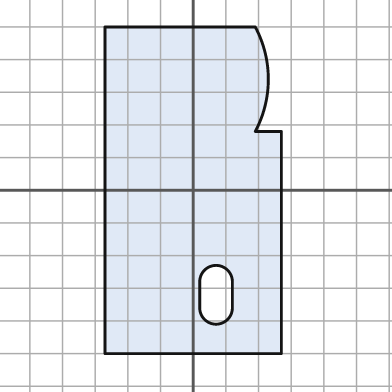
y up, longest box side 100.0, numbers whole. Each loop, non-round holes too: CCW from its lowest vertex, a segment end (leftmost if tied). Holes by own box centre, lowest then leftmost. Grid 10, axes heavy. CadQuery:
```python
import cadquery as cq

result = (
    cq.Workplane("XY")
    .moveTo(-27.0, -50.0)
    .lineTo(27.0, -50.0)
    .lineTo(27.0, 18.0)
    .lineTo(19.0, 18.0)
    .threePointArc((23.0, 34.0), (19.0, 50.0))
    .lineTo(-27.0, 50.0)
    .close()
    .moveTo(2.0, -36.0)
    .threePointArc((7.0, -41.0), (12.0, -36.0))
    .lineTo(12.0, -28.0)
    .threePointArc((7.0, -23.0), (2.0, -28.0))
    .close()
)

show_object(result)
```